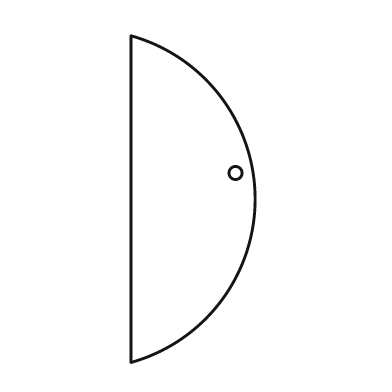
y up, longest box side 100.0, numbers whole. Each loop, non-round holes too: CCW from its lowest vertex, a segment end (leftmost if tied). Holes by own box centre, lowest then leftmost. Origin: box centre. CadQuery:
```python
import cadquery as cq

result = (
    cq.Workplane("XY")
    .moveTo(-19.0, -50.0)
    .threePointArc((19.0, 0.0), (-19.0, 50.0))
    .close()
    .moveTo(13.0, 8.0)
    .circle(2.0)
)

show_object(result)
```